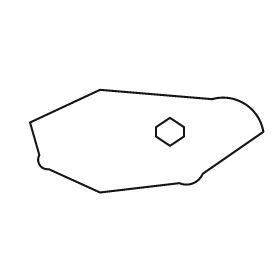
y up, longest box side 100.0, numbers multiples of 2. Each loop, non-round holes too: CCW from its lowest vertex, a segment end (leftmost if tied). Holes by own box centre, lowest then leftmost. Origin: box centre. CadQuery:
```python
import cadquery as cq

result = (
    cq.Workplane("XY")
    .moveTo(-20.0, -22.0)
    .lineTo(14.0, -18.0)
    .threePointArc((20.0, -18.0), (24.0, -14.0))
    .lineTo(50.0, 4.0)
    .threePointArc((42.0, 16.0), (28.0, 18.0))
    .lineTo(-20.0, 22.0)
    .lineTo(-50.0, 8.0)
    .lineTo(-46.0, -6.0)
    .threePointArc((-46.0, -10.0), (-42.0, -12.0))
    .close()
    .moveTo(10.0, -2.0)
    .lineTo(16.0, 2.0)
    .lineTo(16.0, 6.0)
    .lineTo(10.0, 10.0)
    .lineTo(4.0, 6.0)
    .lineTo(4.0, 2.0)
    .close()
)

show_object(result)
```